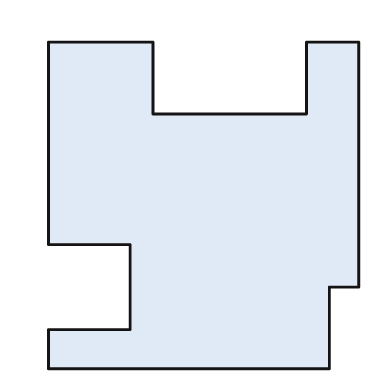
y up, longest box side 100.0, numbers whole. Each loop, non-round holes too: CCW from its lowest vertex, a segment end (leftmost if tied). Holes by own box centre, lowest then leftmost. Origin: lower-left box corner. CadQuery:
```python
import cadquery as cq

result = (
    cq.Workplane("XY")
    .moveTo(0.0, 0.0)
    .lineTo(86.0, 0.0)
    .lineTo(86.0, 25.0)
    .lineTo(95.0, 25.0)
    .lineTo(95.0, 100.0)
    .lineTo(79.0, 100.0)
    .lineTo(79.0, 78.0)
    .lineTo(32.0, 78.0)
    .lineTo(32.0, 100.0)
    .lineTo(0.0, 100.0)
    .lineTo(0.0, 38.0)
    .lineTo(25.0, 38.0)
    .lineTo(25.0, 12.0)
    .lineTo(0.0, 12.0)
    .close()
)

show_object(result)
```